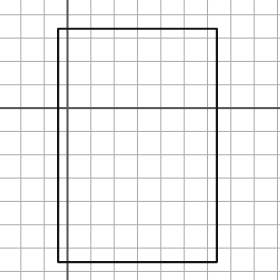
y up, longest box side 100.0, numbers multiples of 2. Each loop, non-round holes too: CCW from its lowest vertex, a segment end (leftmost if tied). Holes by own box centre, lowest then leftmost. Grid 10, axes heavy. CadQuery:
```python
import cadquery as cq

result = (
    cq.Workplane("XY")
    .moveTo(-4.0, -66.0)
    .lineTo(64.0, -66.0)
    .lineTo(64.0, 34.0)
    .lineTo(-4.0, 34.0)
    .close()
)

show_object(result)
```